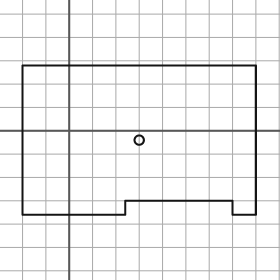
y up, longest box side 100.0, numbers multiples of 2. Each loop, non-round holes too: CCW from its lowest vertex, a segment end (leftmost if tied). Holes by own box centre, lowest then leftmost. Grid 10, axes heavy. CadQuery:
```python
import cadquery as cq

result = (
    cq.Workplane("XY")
    .moveTo(-20.0, -36.0)
    .lineTo(24.0, -36.0)
    .lineTo(24.0, -30.0)
    .lineTo(70.0, -30.0)
    .lineTo(70.0, -36.0)
    .lineTo(80.0, -36.0)
    .lineTo(80.0, 28.0)
    .lineTo(-20.0, 28.0)
    .close()
    .moveTo(30.0, -4.0)
    .circle(2.0)
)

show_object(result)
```